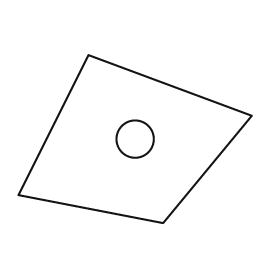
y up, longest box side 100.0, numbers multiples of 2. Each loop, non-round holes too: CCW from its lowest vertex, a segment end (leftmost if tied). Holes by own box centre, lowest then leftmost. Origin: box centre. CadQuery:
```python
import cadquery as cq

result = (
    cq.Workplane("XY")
    .moveTo(12.0, -36.0)
    .lineTo(50.0, 10.0)
    .lineTo(-20.0, 36.0)
    .lineTo(-50.0, -24.0)
    .close()
    .moveTo(0.0, 0.0)
    .circle(8.0)
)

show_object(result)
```